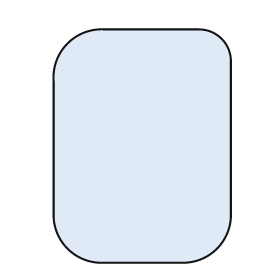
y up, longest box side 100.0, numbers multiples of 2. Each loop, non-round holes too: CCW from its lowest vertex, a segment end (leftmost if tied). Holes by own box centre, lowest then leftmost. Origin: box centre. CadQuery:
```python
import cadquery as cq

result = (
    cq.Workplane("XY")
    .moveTo(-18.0, -50.0)
    .lineTo(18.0, -50.0)
    .threePointArc((32.0, -44.0), (38.0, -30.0))
    .lineTo(38.0, 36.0)
    .threePointArc((34.0, 46.0), (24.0, 50.0))
    .lineTo(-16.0, 50.0)
    .threePointArc((-32.0, 44.0), (-38.0, 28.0))
    .lineTo(-38.0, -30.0)
    .threePointArc((-32.0, -44.0), (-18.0, -50.0))
    .close()
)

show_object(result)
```